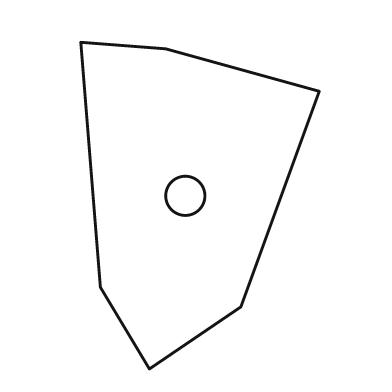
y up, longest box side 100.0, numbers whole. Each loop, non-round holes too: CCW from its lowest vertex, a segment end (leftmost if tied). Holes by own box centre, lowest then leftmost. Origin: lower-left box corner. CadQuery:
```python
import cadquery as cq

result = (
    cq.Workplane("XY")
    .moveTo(21.0, 0.0)
    .lineTo(49.0, 19.0)
    .lineTo(73.0, 85.0)
    .lineTo(26.0, 98.0)
    .lineTo(0.0, 100.0)
    .lineTo(6.0, 25.0)
    .close()
    .moveTo(32.0, 53.0)
    .circle(6.0)
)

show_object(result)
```